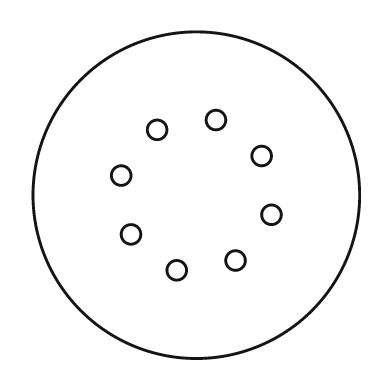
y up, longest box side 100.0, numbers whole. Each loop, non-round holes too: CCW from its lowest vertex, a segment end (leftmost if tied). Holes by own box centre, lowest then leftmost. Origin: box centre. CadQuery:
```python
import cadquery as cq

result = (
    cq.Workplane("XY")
    .moveTo(0.0, 0.0)
    .circle(50.0)
    .moveTo(-6.0, -23.0)
    .circle(3.0)
    .moveTo(12.0, -20.0)
    .circle(3.0)
    .moveTo(-20.0, -12.0)
    .circle(3.0)
    .moveTo(23.0, -6.0)
    .circle(3.0)
    .moveTo(-23.0, 6.0)
    .circle(3.0)
    .moveTo(20.0, 12.0)
    .circle(3.0)
    .moveTo(-12.0, 20.0)
    .circle(3.0)
    .moveTo(6.0, 23.0)
    .circle(3.0)
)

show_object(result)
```